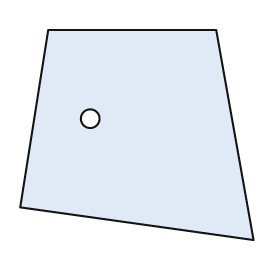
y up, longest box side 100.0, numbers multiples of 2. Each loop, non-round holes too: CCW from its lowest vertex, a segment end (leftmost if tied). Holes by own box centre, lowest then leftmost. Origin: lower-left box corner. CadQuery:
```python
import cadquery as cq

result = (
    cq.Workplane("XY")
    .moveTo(100.0, 0.0)
    .lineTo(84.0, 90.0)
    .lineTo(12.0, 90.0)
    .lineTo(0.0, 14.0)
    .close()
    .moveTo(30.0, 52.0)
    .circle(4.0)
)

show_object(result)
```